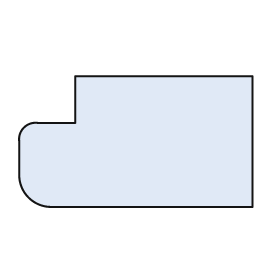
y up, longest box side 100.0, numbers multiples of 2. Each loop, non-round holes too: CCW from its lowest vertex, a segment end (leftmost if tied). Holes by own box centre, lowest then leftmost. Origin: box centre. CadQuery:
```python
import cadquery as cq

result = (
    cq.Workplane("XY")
    .moveTo(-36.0, -28.0)
    .lineTo(50.0, -28.0)
    .lineTo(50.0, 28.0)
    .lineTo(-26.0, 28.0)
    .lineTo(-26.0, 8.0)
    .lineTo(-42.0, 8.0)
    .threePointArc((-48.0, 6.0), (-50.0, 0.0))
    .lineTo(-50.0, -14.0)
    .threePointArc((-46.0, -24.0), (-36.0, -28.0))
    .close()
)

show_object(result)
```